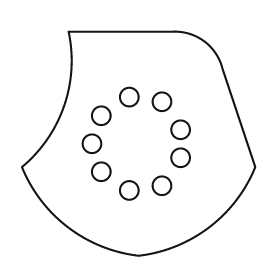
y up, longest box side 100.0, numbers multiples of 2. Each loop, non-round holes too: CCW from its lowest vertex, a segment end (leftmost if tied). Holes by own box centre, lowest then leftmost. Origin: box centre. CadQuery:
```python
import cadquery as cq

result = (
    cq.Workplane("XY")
    .moveTo(0.0, -48.0)
    .threePointArc((30.0, -36.0), (50.0, -10.0))
    .lineTo(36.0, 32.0)
    .threePointArc((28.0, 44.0), (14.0, 48.0))
    .lineTo(-30.0, 48.0)
    .threePointArc((-32.0, 16.0), (-50.0, -10.0))
    .threePointArc((-30.0, -36.0), (0.0, -48.0))
    .close()
    .moveTo(-4.0, -20.0)
    .circle(4.0)
    .moveTo(10.0, -18.0)
    .circle(4.0)
    .moveTo(-16.0, -12.0)
    .circle(4.0)
    .moveTo(18.0, -6.0)
    .circle(4.0)
    .moveTo(-20.0, 0.0)
    .circle(4.0)
    .moveTo(18.0, 6.0)
    .circle(4.0)
    .moveTo(-16.0, 12.0)
    .circle(4.0)
    .moveTo(10.0, 18.0)
    .circle(4.0)
    .moveTo(-4.0, 20.0)
    .circle(4.0)
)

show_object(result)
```